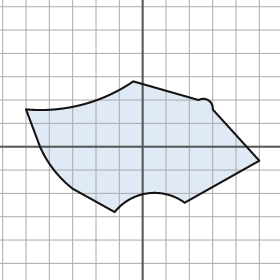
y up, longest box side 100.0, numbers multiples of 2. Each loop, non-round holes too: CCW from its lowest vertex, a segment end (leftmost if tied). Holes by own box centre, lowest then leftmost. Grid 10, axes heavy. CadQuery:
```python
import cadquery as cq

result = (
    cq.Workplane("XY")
    .moveTo(-12.0, -28.0)
    .threePointArc((2.0, -20.0), (18.0, -24.0))
    .lineTo(50.0, -6.0)
    .lineTo(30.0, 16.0)
    .threePointArc((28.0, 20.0), (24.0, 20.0))
    .lineTo(-4.0, 28.0)
    .threePointArc((-26.0, 18.0), (-50.0, 16.0))
    .lineTo(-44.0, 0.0)
    .threePointArc((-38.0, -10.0), (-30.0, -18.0))
    .close()
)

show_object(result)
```